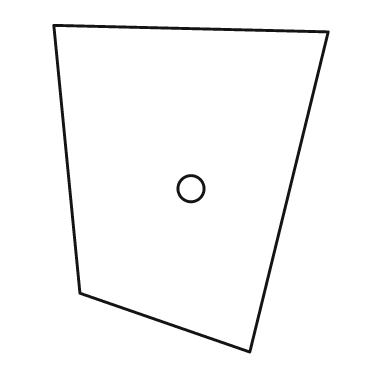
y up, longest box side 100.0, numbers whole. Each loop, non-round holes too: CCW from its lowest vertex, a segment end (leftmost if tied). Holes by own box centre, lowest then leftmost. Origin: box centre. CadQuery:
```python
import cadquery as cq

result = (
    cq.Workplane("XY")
    .moveTo(18.0, -50.0)
    .lineTo(42.0, 48.0)
    .lineTo(-42.0, 50.0)
    .lineTo(-34.0, -32.0)
    .close()
    .moveTo(0.0, 0.0)
    .circle(4.0)
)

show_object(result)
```